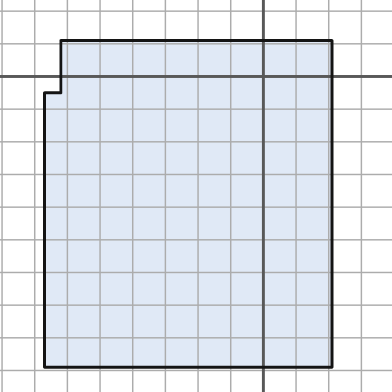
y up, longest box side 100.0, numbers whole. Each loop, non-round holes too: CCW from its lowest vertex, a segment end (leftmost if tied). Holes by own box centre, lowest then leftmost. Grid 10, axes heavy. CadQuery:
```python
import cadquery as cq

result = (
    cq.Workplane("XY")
    .moveTo(-67.0, -89.0)
    .lineTo(21.0, -89.0)
    .lineTo(21.0, 11.0)
    .lineTo(-62.0, 11.0)
    .lineTo(-62.0, -5.0)
    .lineTo(-67.0, -5.0)
    .close()
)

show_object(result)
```